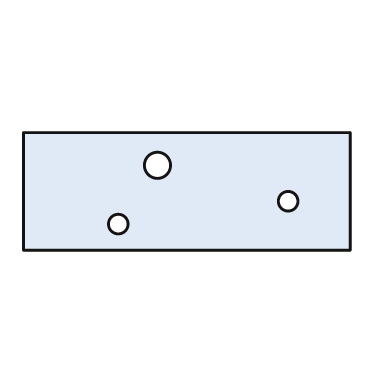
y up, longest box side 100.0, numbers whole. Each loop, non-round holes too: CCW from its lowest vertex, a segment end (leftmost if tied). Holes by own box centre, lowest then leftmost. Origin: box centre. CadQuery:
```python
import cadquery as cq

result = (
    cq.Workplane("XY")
    .moveTo(-50.0, -18.0)
    .lineTo(50.0, -18.0)
    .lineTo(50.0, 18.0)
    .lineTo(-50.0, 18.0)
    .close()
    .moveTo(-21.0, -10.0)
    .circle(3.0)
    .moveTo(31.0, -3.0)
    .circle(3.0)
    .moveTo(-9.0, 8.0)
    .circle(4.0)
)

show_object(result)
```